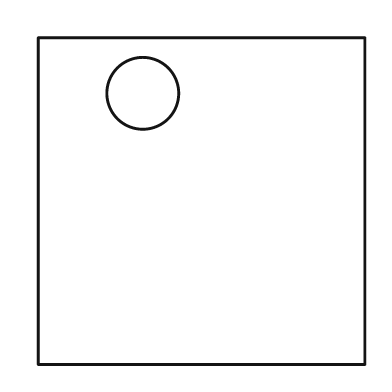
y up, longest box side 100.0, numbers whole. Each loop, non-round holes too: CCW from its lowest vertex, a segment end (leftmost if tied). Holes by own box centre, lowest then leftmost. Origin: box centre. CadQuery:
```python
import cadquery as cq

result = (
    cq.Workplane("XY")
    .moveTo(-50.0, -50.0)
    .lineTo(50.0, -50.0)
    .lineTo(50.0, 50.0)
    .lineTo(-50.0, 50.0)
    .close()
    .moveTo(-18.0, 33.0)
    .circle(11.0)
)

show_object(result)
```